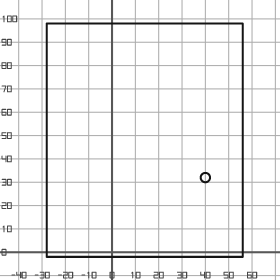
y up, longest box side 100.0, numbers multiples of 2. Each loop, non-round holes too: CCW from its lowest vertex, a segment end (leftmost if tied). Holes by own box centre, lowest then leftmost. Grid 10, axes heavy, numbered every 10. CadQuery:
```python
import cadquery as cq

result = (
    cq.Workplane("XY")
    .moveTo(-28.0, -2.0)
    .lineTo(56.0, -2.0)
    .lineTo(56.0, 98.0)
    .lineTo(-28.0, 98.0)
    .close()
    .moveTo(40.0, 32.0)
    .circle(2.0)
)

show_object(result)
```